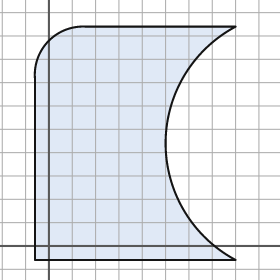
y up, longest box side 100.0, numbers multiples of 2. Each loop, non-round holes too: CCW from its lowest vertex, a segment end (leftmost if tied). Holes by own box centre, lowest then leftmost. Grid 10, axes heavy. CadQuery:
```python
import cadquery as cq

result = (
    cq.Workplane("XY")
    .moveTo(-6.0, -6.0)
    .lineTo(80.0, -6.0)
    .threePointArc((50.0, 44.0), (80.0, 94.0))
    .lineTo(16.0, 94.0)
    .threePointArc((0.0, 88.0), (-6.0, 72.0))
    .close()
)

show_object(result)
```